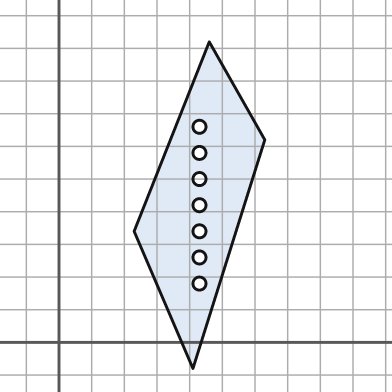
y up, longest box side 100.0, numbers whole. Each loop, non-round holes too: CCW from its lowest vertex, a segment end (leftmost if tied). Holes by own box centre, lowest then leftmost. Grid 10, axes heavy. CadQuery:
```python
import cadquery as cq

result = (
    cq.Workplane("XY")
    .moveTo(41.0, -8.0)
    .lineTo(63.0, 62.0)
    .lineTo(46.0, 92.0)
    .lineTo(23.0, 34.0)
    .close()
    .moveTo(43.0, 18.0)
    .circle(2.0)
    .moveTo(43.0, 26.0)
    .circle(2.0)
    .moveTo(43.0, 34.0)
    .circle(2.0)
    .moveTo(43.0, 42.0)
    .circle(2.0)
    .moveTo(43.0, 50.0)
    .circle(2.0)
    .moveTo(43.0, 58.0)
    .circle(2.0)
    .moveTo(43.0, 66.0)
    .circle(2.0)
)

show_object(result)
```